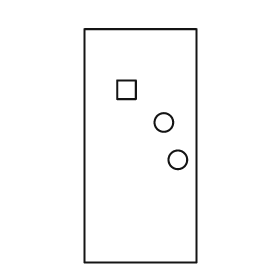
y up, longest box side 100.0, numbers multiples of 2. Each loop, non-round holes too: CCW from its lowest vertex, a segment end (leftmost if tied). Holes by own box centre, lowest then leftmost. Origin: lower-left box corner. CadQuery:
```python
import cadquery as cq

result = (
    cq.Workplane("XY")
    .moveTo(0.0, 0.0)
    .lineTo(48.0, 0.0)
    .lineTo(48.0, 100.0)
    .lineTo(0.0, 100.0)
    .close()
    .moveTo(40.0, 44.0)
    .circle(4.0)
    .moveTo(34.0, 60.0)
    .circle(4.0)
    .moveTo(14.0, 70.0)
    .lineTo(22.0, 70.0)
    .lineTo(22.0, 78.0)
    .lineTo(14.0, 78.0)
    .close()
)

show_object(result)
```